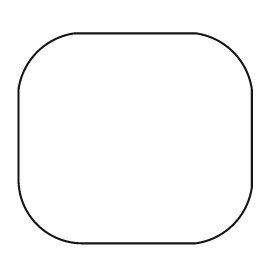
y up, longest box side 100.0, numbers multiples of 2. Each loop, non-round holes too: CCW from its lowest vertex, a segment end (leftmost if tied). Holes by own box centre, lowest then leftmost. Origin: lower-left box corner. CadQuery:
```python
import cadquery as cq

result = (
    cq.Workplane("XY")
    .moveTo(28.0, 0.0)
    .lineTo(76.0, 0.0)
    .threePointArc((92.0, 8.0), (100.0, 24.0))
    .lineTo(100.0, 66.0)
    .threePointArc((92.0, 82.0), (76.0, 90.0))
    .lineTo(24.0, 90.0)
    .threePointArc((8.0, 82.0), (0.0, 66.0))
    .lineTo(0.0, 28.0)
    .threePointArc((8.0, 8.0), (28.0, 0.0))
    .close()
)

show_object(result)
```